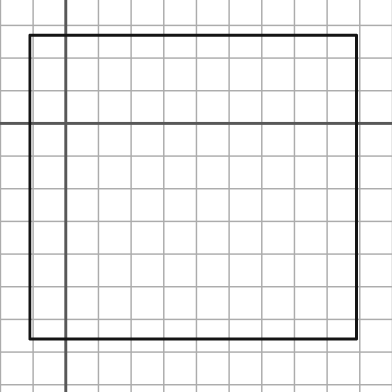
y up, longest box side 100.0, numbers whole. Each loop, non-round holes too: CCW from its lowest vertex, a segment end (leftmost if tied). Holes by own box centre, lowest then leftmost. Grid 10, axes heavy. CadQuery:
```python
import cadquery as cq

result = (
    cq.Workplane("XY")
    .moveTo(-11.0, -66.0)
    .lineTo(89.0, -66.0)
    .lineTo(89.0, 27.0)
    .lineTo(-11.0, 27.0)
    .close()
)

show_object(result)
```